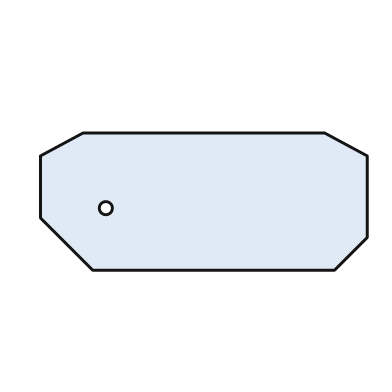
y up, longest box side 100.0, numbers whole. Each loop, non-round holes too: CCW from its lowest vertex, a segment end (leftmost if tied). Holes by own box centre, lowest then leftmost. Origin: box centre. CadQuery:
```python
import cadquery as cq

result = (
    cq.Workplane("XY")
    .moveTo(-34.0, -21.0)
    .lineTo(40.0, -21.0)
    .lineTo(50.0, -11.0)
    .lineTo(50.0, 14.0)
    .lineTo(37.0, 21.0)
    .lineTo(-37.0, 21.0)
    .lineTo(-50.0, 14.0)
    .lineTo(-50.0, -5.0)
    .close()
    .moveTo(-30.0, -2.0)
    .circle(2.0)
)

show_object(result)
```